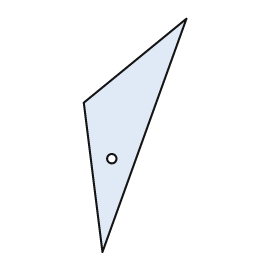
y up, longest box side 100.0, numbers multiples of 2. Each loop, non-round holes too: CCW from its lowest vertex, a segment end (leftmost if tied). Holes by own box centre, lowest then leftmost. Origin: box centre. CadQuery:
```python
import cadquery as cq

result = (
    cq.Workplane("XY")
    .moveTo(-14.0, -50.0)
    .lineTo(22.0, 50.0)
    .lineTo(-22.0, 14.0)
    .close()
    .moveTo(-10.0, -10.0)
    .circle(2.0)
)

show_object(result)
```